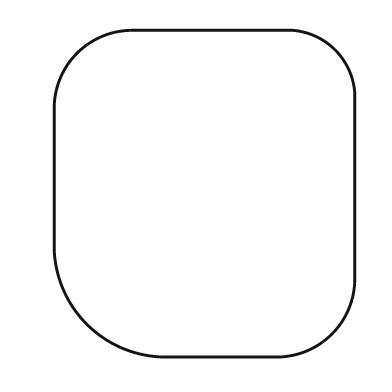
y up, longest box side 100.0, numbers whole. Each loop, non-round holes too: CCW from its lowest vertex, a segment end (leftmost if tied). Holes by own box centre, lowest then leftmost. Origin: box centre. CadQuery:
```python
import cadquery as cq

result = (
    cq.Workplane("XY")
    .moveTo(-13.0, -50.0)
    .lineTo(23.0, -50.0)
    .threePointArc((39.0, -43.0), (46.0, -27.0))
    .lineTo(46.0, 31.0)
    .threePointArc((40.0, 44.0), (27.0, 50.0))
    .lineTo(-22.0, 50.0)
    .threePointArc((-39.0, 43.0), (-46.0, 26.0))
    .lineTo(-46.0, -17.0)
    .threePointArc((-36.0, -40.0), (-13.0, -50.0))
    .close()
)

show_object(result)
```